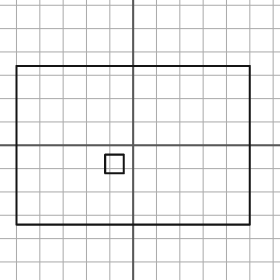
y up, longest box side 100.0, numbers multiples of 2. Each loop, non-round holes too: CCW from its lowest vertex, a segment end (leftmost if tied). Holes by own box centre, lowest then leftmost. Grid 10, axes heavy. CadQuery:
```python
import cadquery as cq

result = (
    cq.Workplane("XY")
    .moveTo(-50.0, -34.0)
    .lineTo(50.0, -34.0)
    .lineTo(50.0, 34.0)
    .lineTo(-50.0, 34.0)
    .close()
    .moveTo(-12.0, -12.0)
    .lineTo(-4.0, -12.0)
    .lineTo(-4.0, -4.0)
    .lineTo(-12.0, -4.0)
    .close()
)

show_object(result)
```